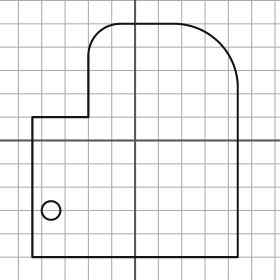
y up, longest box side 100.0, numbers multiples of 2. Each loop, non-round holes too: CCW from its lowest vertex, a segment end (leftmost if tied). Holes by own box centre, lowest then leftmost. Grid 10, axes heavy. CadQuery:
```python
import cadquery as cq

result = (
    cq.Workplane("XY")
    .moveTo(-44.0, -50.0)
    .lineTo(44.0, -50.0)
    .lineTo(44.0, 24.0)
    .threePointArc((36.0, 42.0), (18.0, 50.0))
    .lineTo(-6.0, 50.0)
    .threePointArc((-16.0, 46.0), (-20.0, 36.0))
    .lineTo(-20.0, 10.0)
    .lineTo(-44.0, 10.0)
    .close()
    .moveTo(-36.0, -30.0)
    .circle(4.0)
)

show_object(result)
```